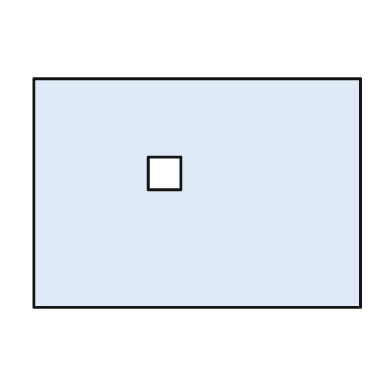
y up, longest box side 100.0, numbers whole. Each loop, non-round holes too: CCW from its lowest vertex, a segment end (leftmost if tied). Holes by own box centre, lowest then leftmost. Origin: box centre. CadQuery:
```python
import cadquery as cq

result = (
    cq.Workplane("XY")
    .moveTo(-50.0, -35.0)
    .lineTo(50.0, -35.0)
    .lineTo(50.0, 35.0)
    .lineTo(-50.0, 35.0)
    .close()
    .moveTo(-15.0, 1.0)
    .lineTo(-5.0, 1.0)
    .lineTo(-5.0, 11.0)
    .lineTo(-15.0, 11.0)
    .close()
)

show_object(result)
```